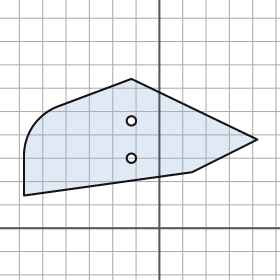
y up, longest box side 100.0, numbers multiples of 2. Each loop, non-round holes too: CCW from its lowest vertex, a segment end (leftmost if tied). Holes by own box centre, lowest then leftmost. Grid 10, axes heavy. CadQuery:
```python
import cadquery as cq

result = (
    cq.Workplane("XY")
    .moveTo(-58.0, 14.0)
    .lineTo(14.0, 24.0)
    .lineTo(42.0, 38.0)
    .lineTo(-12.0, 64.0)
    .lineTo(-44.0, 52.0)
    .threePointArc((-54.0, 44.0), (-58.0, 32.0))
    .close()
    .moveTo(-12.0, 30.0)
    .circle(2.0)
    .moveTo(-12.0, 46.0)
    .circle(2.0)
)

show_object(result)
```